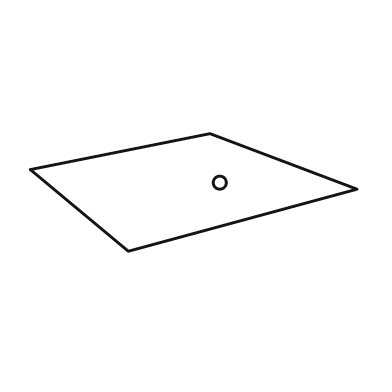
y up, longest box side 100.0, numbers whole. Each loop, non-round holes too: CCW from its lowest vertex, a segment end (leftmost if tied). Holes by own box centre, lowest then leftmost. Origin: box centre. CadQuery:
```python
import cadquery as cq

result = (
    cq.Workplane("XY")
    .moveTo(-20.0, -18.0)
    .lineTo(50.0, 1.0)
    .lineTo(5.0, 18.0)
    .lineTo(-50.0, 7.0)
    .close()
    .moveTo(8.0, 3.0)
    .circle(2.0)
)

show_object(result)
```